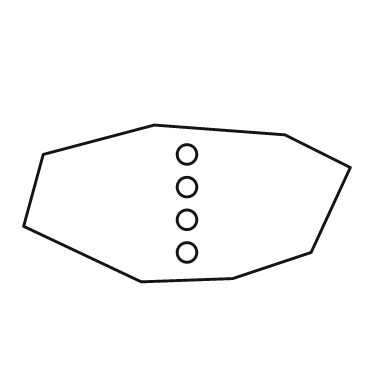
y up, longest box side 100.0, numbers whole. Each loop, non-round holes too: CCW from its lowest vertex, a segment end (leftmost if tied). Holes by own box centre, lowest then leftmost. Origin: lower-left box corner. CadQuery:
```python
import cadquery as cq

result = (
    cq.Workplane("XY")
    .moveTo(36.0, 0.0)
    .lineTo(64.0, 1.0)
    .lineTo(88.0, 9.0)
    .lineTo(100.0, 35.0)
    .lineTo(80.0, 45.0)
    .lineTo(40.0, 48.0)
    .lineTo(6.0, 39.0)
    .lineTo(0.0, 17.0)
    .close()
    .moveTo(50.0, 9.0)
    .circle(3.0)
    .moveTo(50.0, 19.0)
    .circle(3.0)
    .moveTo(50.0, 29.0)
    .circle(3.0)
    .moveTo(50.0, 39.0)
    .circle(3.0)
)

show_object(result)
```